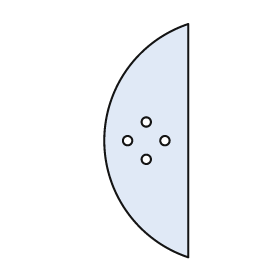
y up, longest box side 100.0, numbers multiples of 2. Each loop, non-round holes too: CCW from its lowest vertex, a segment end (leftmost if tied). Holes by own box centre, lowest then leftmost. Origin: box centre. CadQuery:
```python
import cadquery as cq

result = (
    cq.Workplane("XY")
    .moveTo(18.0, -50.0)
    .lineTo(18.0, 50.0)
    .threePointArc((-18.0, 0.0), (18.0, -50.0))
    .close()
    .moveTo(0.0, -8.0)
    .circle(2.0)
    .moveTo(-8.0, 0.0)
    .circle(2.0)
    .moveTo(8.0, 0.0)
    .circle(2.0)
    .moveTo(0.0, 8.0)
    .circle(2.0)
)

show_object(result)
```